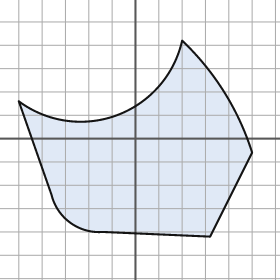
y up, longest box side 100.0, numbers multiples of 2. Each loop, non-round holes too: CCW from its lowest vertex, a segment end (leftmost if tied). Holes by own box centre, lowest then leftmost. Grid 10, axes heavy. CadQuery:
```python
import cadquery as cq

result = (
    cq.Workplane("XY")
    .moveTo(32.0, -42.0)
    .lineTo(50.0, -6.0)
    .threePointArc((38.0, 20.0), (20.0, 42.0))
    .threePointArc((-8.0, 10.0), (-50.0, 16.0))
    .lineTo(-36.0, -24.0)
    .threePointArc((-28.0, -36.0), (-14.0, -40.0))
    .close()
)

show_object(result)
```